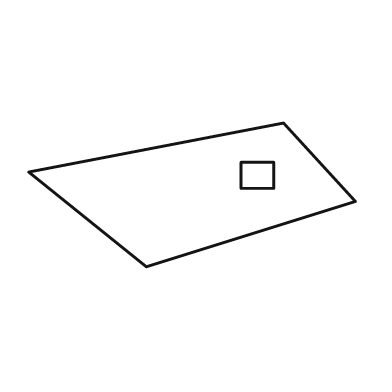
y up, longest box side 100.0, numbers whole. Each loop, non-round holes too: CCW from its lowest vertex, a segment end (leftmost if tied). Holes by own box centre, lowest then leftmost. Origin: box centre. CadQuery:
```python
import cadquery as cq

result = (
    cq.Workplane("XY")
    .moveTo(-14.0, -22.0)
    .lineTo(50.0, -2.0)
    .lineTo(28.0, 22.0)
    .lineTo(-50.0, 7.0)
    .close()
    .moveTo(15.0, 2.0)
    .lineTo(25.0, 2.0)
    .lineTo(25.0, 10.0)
    .lineTo(15.0, 10.0)
    .close()
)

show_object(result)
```